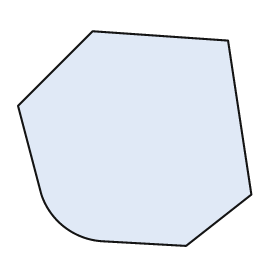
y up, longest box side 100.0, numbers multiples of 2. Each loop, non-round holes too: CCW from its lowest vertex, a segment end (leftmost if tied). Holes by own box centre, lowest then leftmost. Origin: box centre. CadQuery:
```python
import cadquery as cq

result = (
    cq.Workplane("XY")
    .moveTo(22.0, -46.0)
    .lineTo(50.0, -24.0)
    .lineTo(40.0, 42.0)
    .lineTo(-18.0, 46.0)
    .lineTo(-50.0, 14.0)
    .lineTo(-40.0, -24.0)
    .threePointArc((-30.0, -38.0), (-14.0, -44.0))
    .close()
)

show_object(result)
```